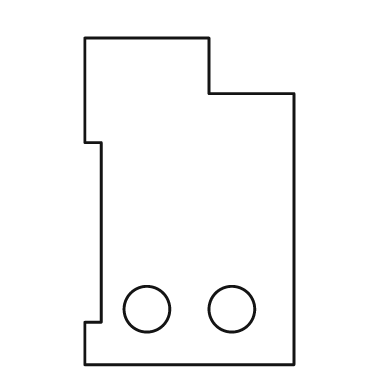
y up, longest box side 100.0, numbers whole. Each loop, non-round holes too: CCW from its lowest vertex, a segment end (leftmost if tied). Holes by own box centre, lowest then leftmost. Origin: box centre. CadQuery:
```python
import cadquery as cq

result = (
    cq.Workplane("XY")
    .moveTo(-32.0, -50.0)
    .lineTo(32.0, -50.0)
    .lineTo(32.0, 33.0)
    .lineTo(6.0, 33.0)
    .lineTo(6.0, 50.0)
    .lineTo(-32.0, 50.0)
    .lineTo(-32.0, 18.0)
    .lineTo(-27.0, 18.0)
    .lineTo(-27.0, -37.0)
    .lineTo(-32.0, -37.0)
    .close()
    .moveTo(-13.0, -33.0)
    .circle(7.0)
    .moveTo(13.0, -33.0)
    .circle(7.0)
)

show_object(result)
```